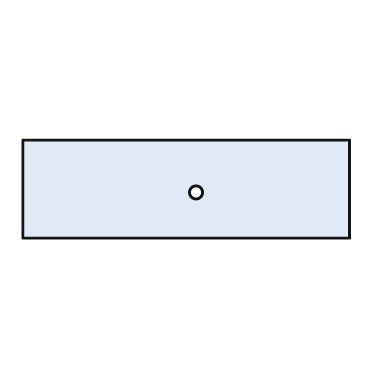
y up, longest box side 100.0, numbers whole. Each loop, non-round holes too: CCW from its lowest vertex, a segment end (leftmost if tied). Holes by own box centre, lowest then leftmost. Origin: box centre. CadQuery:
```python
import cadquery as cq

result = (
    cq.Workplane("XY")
    .moveTo(-50.0, -15.0)
    .lineTo(50.0, -15.0)
    .lineTo(50.0, 15.0)
    .lineTo(-50.0, 15.0)
    .close()
    .moveTo(3.0, -1.0)
    .circle(2.0)
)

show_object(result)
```